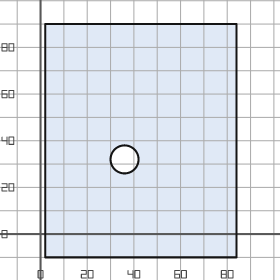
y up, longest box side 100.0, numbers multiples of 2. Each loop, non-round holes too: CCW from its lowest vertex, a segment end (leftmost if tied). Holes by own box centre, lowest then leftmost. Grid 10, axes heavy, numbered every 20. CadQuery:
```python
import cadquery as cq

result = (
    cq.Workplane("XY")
    .moveTo(2.0, -10.0)
    .lineTo(84.0, -10.0)
    .lineTo(84.0, 90.0)
    .lineTo(2.0, 90.0)
    .close()
    .moveTo(36.0, 32.0)
    .circle(6.0)
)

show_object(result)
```